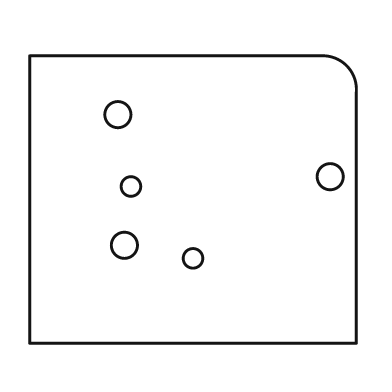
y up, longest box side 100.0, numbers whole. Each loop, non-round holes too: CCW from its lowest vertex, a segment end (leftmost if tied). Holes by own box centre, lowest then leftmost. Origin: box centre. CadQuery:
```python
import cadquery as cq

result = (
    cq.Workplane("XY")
    .moveTo(-50.0, -44.0)
    .lineTo(50.0, -44.0)
    .lineTo(50.0, 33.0)
    .threePointArc((47.0, 41.0), (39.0, 44.0))
    .lineTo(-50.0, 44.0)
    .close()
    .moveTo(0.0, -18.0)
    .circle(3.0)
    .moveTo(-21.0, -14.0)
    .circle(4.0)
    .moveTo(-19.0, 4.0)
    .circle(3.0)
    .moveTo(42.0, 7.0)
    .circle(4.0)
    .moveTo(-23.0, 26.0)
    .circle(4.0)
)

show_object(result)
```